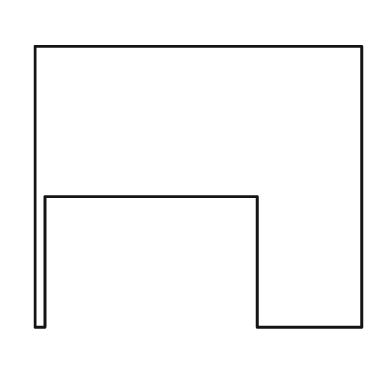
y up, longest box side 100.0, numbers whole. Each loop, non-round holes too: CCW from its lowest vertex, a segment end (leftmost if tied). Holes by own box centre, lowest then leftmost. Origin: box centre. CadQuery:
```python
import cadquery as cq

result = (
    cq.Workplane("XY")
    .moveTo(-50.0, -43.0)
    .lineTo(-47.0, -43.0)
    .lineTo(-47.0, -3.0)
    .lineTo(18.0, -3.0)
    .lineTo(18.0, -43.0)
    .lineTo(50.0, -43.0)
    .lineTo(50.0, 43.0)
    .lineTo(-50.0, 43.0)
    .close()
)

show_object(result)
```